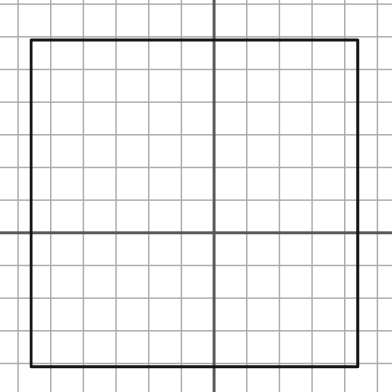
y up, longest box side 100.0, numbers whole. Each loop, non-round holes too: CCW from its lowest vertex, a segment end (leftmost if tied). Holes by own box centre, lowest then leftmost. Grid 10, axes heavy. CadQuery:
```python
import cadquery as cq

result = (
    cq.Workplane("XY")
    .moveTo(-56.0, -41.0)
    .lineTo(44.0, -41.0)
    .lineTo(44.0, 59.0)
    .lineTo(-56.0, 59.0)
    .close()
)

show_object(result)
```